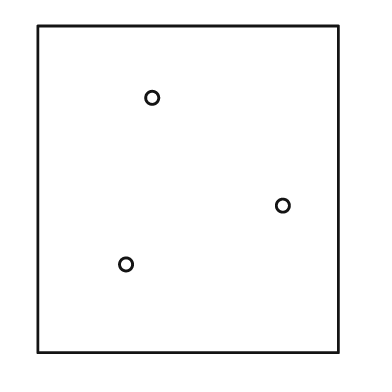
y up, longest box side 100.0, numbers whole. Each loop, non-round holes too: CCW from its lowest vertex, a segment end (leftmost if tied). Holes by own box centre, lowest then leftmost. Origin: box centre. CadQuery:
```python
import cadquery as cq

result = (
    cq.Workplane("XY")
    .moveTo(-46.0, -50.0)
    .lineTo(46.0, -50.0)
    .lineTo(46.0, 50.0)
    .lineTo(-46.0, 50.0)
    .close()
    .moveTo(-19.0, -23.0)
    .circle(2.0)
    .moveTo(29.0, -5.0)
    .circle(2.0)
    .moveTo(-11.0, 28.0)
    .circle(2.0)
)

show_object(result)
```